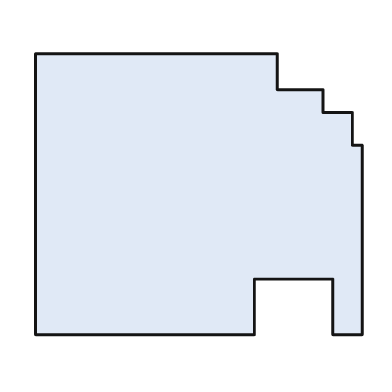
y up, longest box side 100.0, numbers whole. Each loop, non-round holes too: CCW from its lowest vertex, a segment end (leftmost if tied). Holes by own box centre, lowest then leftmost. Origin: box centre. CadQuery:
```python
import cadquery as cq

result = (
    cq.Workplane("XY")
    .moveTo(-50.0, -43.0)
    .lineTo(17.0, -43.0)
    .lineTo(17.0, -26.0)
    .lineTo(41.0, -26.0)
    .lineTo(41.0, -43.0)
    .lineTo(50.0, -43.0)
    .lineTo(50.0, 15.0)
    .lineTo(47.0, 15.0)
    .lineTo(47.0, 25.0)
    .lineTo(38.0, 25.0)
    .lineTo(38.0, 32.0)
    .lineTo(24.0, 32.0)
    .lineTo(24.0, 43.0)
    .lineTo(-50.0, 43.0)
    .close()
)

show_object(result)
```